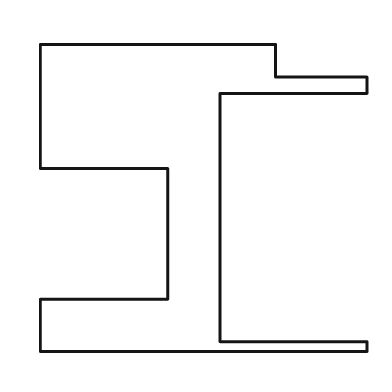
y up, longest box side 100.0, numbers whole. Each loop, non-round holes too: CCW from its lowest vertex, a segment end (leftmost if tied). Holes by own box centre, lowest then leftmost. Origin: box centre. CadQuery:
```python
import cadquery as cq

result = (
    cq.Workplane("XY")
    .moveTo(-50.0, -47.0)
    .lineTo(50.0, -47.0)
    .lineTo(50.0, -44.0)
    .lineTo(5.0, -44.0)
    .lineTo(5.0, 32.0)
    .lineTo(50.0, 32.0)
    .lineTo(50.0, 37.0)
    .lineTo(22.0, 37.0)
    .lineTo(22.0, 47.0)
    .lineTo(-50.0, 47.0)
    .lineTo(-50.0, 9.0)
    .lineTo(-11.0, 9.0)
    .lineTo(-11.0, -31.0)
    .lineTo(-50.0, -31.0)
    .close()
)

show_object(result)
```